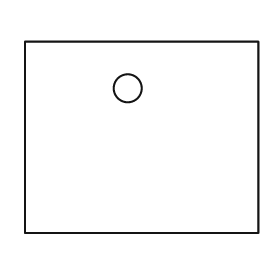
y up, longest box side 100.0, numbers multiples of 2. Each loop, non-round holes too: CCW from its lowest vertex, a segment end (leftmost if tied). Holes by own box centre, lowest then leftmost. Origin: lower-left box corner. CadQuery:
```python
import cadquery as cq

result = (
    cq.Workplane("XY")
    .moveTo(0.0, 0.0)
    .lineTo(100.0, 0.0)
    .lineTo(100.0, 82.0)
    .lineTo(0.0, 82.0)
    .close()
    .moveTo(44.0, 62.0)
    .circle(6.0)
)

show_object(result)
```